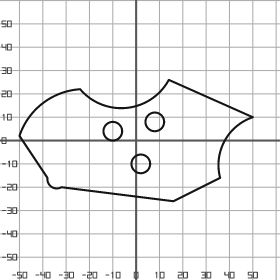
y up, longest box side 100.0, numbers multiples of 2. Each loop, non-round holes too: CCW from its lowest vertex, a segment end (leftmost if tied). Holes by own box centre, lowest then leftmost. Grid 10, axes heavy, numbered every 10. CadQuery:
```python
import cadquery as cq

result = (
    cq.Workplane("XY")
    .moveTo(16.0, -26.0)
    .lineTo(36.0, -16.0)
    .threePointArc((38.0, 0.0), (50.0, 10.0))
    .lineTo(14.0, 26.0)
    .threePointArc((-4.0, 14.0), (-24.0, 22.0))
    .threePointArc((-40.0, 16.0), (-50.0, 2.0))
    .lineTo(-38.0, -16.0)
    .threePointArc((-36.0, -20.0), (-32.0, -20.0))
    .close()
    .moveTo(2.0, -10.0)
    .circle(4.0)
    .moveTo(-10.0, 4.0)
    .circle(4.0)
    .moveTo(8.0, 8.0)
    .circle(4.0)
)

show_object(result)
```